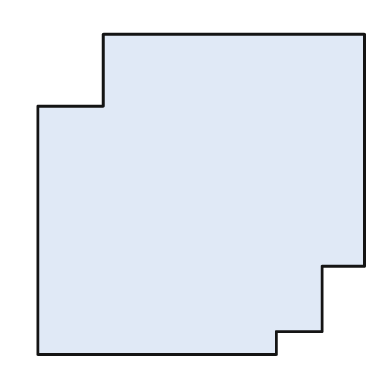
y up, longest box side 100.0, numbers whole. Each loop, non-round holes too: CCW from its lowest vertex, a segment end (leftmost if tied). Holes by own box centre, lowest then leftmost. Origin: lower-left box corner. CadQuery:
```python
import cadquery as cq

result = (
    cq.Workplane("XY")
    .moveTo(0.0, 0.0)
    .lineTo(73.0, 0.0)
    .lineTo(73.0, 7.0)
    .lineTo(87.0, 7.0)
    .lineTo(87.0, 27.0)
    .lineTo(100.0, 27.0)
    .lineTo(100.0, 98.0)
    .lineTo(20.0, 98.0)
    .lineTo(20.0, 76.0)
    .lineTo(0.0, 76.0)
    .close()
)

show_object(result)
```